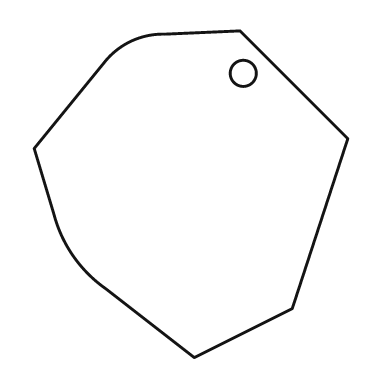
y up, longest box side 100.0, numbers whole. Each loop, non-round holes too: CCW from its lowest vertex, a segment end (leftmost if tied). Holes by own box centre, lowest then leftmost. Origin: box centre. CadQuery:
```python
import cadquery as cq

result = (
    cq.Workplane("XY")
    .moveTo(1.0, -50.0)
    .lineTo(31.0, -35.0)
    .lineTo(48.0, 17.0)
    .lineTo(15.0, 50.0)
    .lineTo(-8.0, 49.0)
    .threePointArc((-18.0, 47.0), (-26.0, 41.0))
    .lineTo(-48.0, 14.0)
    .lineTo(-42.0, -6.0)
    .threePointArc((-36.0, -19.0), (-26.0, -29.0))
    .close()
    .moveTo(16.0, 37.0)
    .circle(4.0)
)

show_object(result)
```